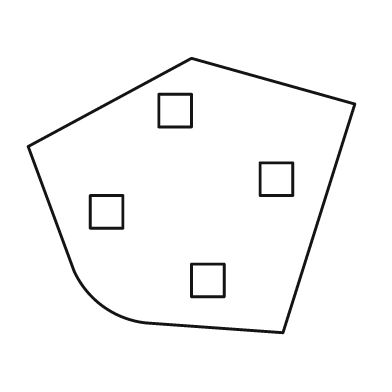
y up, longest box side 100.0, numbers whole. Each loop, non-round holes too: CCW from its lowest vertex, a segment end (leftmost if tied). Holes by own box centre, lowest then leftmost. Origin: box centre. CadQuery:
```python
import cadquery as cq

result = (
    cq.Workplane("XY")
    .moveTo(28.0, -42.0)
    .lineTo(50.0, 28.0)
    .lineTo(0.0, 42.0)
    .lineTo(-50.0, 15.0)
    .lineTo(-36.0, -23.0)
    .threePointArc((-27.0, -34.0), (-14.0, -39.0))
    .close()
    .moveTo(0.0, -31.0)
    .lineTo(10.0, -31.0)
    .lineTo(10.0, -21.0)
    .lineTo(0.0, -21.0)
    .close()
    .moveTo(-31.0, -10.0)
    .lineTo(-21.0, -10.0)
    .lineTo(-21.0, 0.0)
    .lineTo(-31.0, 0.0)
    .close()
    .moveTo(21.0, 0.0)
    .lineTo(31.0, 0.0)
    .lineTo(31.0, 10.0)
    .lineTo(21.0, 10.0)
    .close()
    .moveTo(-10.0, 21.0)
    .lineTo(0.0, 21.0)
    .lineTo(0.0, 31.0)
    .lineTo(-10.0, 31.0)
    .close()
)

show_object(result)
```